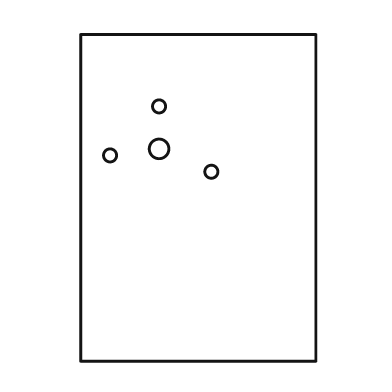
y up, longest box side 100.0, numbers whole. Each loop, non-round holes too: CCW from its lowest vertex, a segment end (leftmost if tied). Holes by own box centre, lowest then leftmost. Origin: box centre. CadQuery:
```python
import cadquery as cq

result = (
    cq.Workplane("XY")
    .moveTo(-36.0, -50.0)
    .lineTo(36.0, -50.0)
    .lineTo(36.0, 50.0)
    .lineTo(-36.0, 50.0)
    .close()
    .moveTo(4.0, 8.0)
    .circle(2.0)
    .moveTo(-27.0, 13.0)
    .circle(2.0)
    .moveTo(-12.0, 15.0)
    .circle(3.0)
    .moveTo(-12.0, 28.0)
    .circle(2.0)
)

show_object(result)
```